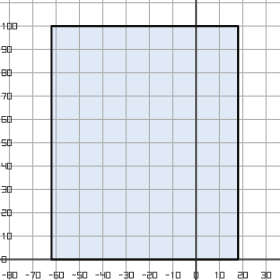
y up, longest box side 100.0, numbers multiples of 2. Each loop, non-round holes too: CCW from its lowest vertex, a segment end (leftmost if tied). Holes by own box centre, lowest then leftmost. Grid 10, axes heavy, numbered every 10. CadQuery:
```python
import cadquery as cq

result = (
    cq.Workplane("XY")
    .moveTo(-62.0, 0.0)
    .lineTo(18.0, 0.0)
    .lineTo(18.0, 100.0)
    .lineTo(-62.0, 100.0)
    .close()
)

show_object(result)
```